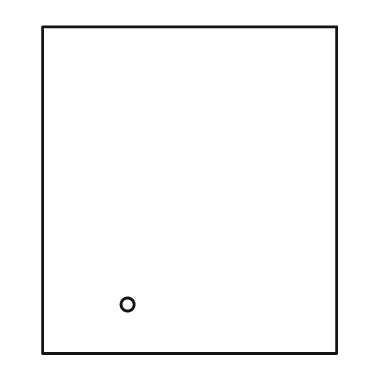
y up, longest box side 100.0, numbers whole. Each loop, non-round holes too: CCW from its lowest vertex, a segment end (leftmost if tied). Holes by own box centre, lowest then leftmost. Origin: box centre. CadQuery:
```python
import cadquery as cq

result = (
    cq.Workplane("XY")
    .moveTo(-45.0, -50.0)
    .lineTo(45.0, -50.0)
    .lineTo(45.0, 50.0)
    .lineTo(-45.0, 50.0)
    .close()
    .moveTo(-19.0, -35.0)
    .circle(2.0)
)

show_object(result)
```